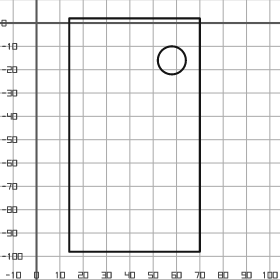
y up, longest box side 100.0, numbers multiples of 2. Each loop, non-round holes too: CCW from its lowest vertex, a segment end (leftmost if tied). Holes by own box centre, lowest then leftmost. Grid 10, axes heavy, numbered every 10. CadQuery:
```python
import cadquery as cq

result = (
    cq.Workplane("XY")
    .moveTo(14.0, -98.0)
    .lineTo(70.0, -98.0)
    .lineTo(70.0, 2.0)
    .lineTo(14.0, 2.0)
    .close()
    .moveTo(58.0, -16.0)
    .circle(6.0)
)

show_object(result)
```